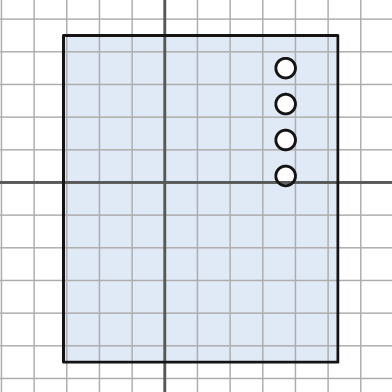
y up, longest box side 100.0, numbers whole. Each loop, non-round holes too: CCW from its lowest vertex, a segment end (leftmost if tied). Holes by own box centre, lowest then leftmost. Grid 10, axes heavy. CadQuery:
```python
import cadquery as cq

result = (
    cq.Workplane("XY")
    .moveTo(-31.0, -55.0)
    .lineTo(53.0, -55.0)
    .lineTo(53.0, 45.0)
    .lineTo(-31.0, 45.0)
    .close()
    .moveTo(37.0, 2.0)
    .circle(3.0)
    .moveTo(37.0, 13.0)
    .circle(3.0)
    .moveTo(37.0, 24.0)
    .circle(3.0)
    .moveTo(37.0, 35.0)
    .circle(3.0)
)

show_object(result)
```